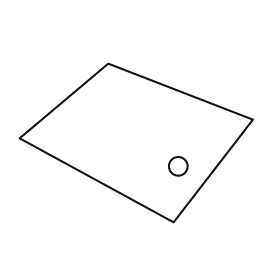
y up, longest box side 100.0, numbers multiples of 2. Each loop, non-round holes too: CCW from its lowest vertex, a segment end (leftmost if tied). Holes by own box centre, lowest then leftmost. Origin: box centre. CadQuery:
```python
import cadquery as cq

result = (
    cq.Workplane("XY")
    .moveTo(16.0, -34.0)
    .lineTo(50.0, 10.0)
    .lineTo(-12.0, 34.0)
    .lineTo(-50.0, 2.0)
    .close()
    .moveTo(18.0, -10.0)
    .circle(4.0)
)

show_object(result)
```